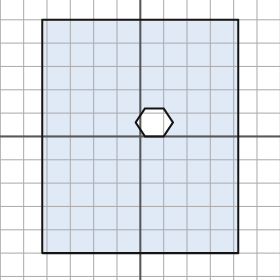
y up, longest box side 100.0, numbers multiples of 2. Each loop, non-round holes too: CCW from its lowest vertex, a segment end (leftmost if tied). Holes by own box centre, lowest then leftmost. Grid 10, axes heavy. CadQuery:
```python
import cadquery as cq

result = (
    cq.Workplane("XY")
    .moveTo(-42.0, -50.0)
    .lineTo(42.0, -50.0)
    .lineTo(42.0, 50.0)
    .lineTo(-42.0, 50.0)
    .close()
    .moveTo(2.0, 0.0)
    .lineTo(10.0, 0.0)
    .lineTo(14.0, 6.0)
    .lineTo(10.0, 12.0)
    .lineTo(2.0, 12.0)
    .lineTo(-2.0, 6.0)
    .close()
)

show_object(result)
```